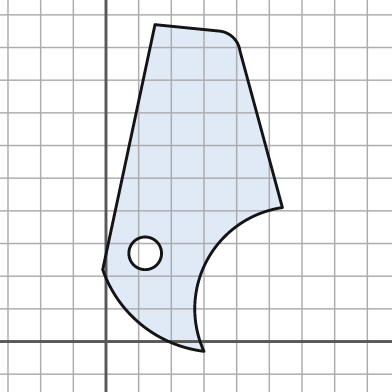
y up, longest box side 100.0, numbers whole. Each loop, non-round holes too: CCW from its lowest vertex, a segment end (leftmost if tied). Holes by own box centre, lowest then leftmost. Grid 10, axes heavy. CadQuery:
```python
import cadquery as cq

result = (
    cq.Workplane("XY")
    .moveTo(30.0, -3.0)
    .threePointArc((31.0, 25.0), (54.0, 41.0))
    .lineTo(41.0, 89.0)
    .threePointArc((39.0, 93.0), (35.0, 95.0))
    .lineTo(15.0, 97.0)
    .lineTo(-1.0, 22.0)
    .threePointArc((11.0, 5.0), (30.0, -3.0))
    .close()
    .moveTo(12.0, 27.0)
    .circle(5.0)
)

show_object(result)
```